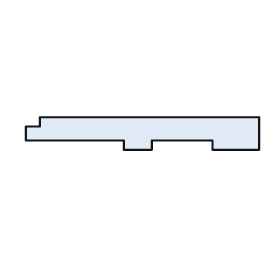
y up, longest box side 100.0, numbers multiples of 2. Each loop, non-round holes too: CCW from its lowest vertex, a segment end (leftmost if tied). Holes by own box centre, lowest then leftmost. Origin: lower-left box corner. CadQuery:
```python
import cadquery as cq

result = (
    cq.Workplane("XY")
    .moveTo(42.0, 0.0)
    .lineTo(54.0, 0.0)
    .lineTo(54.0, 4.0)
    .lineTo(80.0, 4.0)
    .lineTo(80.0, 0.0)
    .lineTo(100.0, 0.0)
    .lineTo(100.0, 14.0)
    .lineTo(6.0, 14.0)
    .lineTo(6.0, 10.0)
    .lineTo(0.0, 10.0)
    .lineTo(0.0, 4.0)
    .lineTo(42.0, 4.0)
    .close()
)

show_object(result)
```